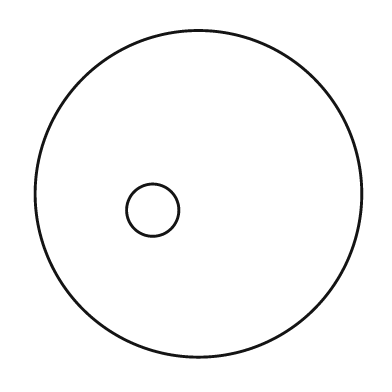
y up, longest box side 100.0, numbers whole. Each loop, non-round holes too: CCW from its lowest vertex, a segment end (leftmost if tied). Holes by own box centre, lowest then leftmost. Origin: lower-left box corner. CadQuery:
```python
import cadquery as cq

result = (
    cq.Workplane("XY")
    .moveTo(50.0, 50.0)
    .circle(50.0)
    .moveTo(36.0, 45.0)
    .circle(8.0)
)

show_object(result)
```